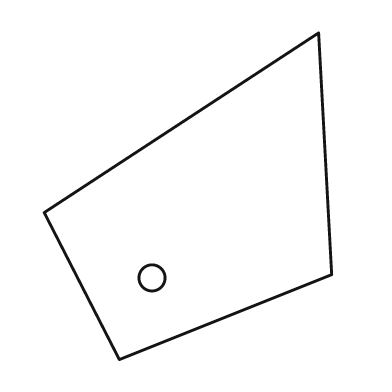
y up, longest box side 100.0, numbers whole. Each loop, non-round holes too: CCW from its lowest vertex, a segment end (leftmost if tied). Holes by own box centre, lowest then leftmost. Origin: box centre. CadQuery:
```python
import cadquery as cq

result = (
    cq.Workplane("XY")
    .moveTo(-21.0, -50.0)
    .lineTo(44.0, -24.0)
    .lineTo(40.0, 50.0)
    .lineTo(-44.0, -5.0)
    .close()
    .moveTo(-11.0, -25.0)
    .circle(4.0)
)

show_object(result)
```